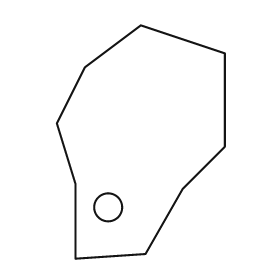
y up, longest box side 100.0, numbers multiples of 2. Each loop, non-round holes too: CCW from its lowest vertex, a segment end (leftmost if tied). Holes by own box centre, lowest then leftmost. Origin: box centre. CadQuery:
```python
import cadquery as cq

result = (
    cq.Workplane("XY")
    .moveTo(-28.0, -50.0)
    .lineTo(2.0, -48.0)
    .lineTo(18.0, -20.0)
    .lineTo(36.0, -2.0)
    .lineTo(36.0, 38.0)
    .lineTo(0.0, 50.0)
    .lineTo(-24.0, 32.0)
    .lineTo(-36.0, 8.0)
    .lineTo(-28.0, -18.0)
    .close()
    .moveTo(-14.0, -28.0)
    .circle(6.0)
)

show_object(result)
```